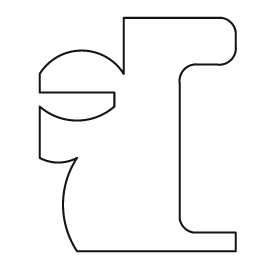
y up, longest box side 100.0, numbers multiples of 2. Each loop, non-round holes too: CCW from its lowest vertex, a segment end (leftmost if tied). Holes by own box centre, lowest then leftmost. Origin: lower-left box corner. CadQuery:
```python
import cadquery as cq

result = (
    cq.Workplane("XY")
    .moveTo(16.0, 0.0)
    .lineTo(84.0, 0.0)
    .lineTo(84.0, 8.0)
    .lineTo(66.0, 8.0)
    .threePointArc((62.0, 10.0), (60.0, 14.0))
    .lineTo(60.0, 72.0)
    .threePointArc((62.0, 78.0), (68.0, 80.0))
    .lineTo(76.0, 80.0)
    .threePointArc((82.0, 82.0), (84.0, 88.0))
    .lineTo(84.0, 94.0)
    .threePointArc((82.0, 98.0), (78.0, 100.0))
    .lineTo(36.0, 100.0)
    .lineTo(36.0, 76.0)
    .threePointArc((18.0, 86.0), (0.0, 76.0))
    .lineTo(0.0, 68.0)
    .lineTo(32.0, 68.0)
    .lineTo(32.0, 62.0)
    .threePointArc((16.0, 56.0), (0.0, 62.0))
    .lineTo(0.0, 40.0)
    .threePointArc((8.0, 38.0), (16.0, 40.0))
    .threePointArc((10.0, 20.0), (16.0, 0.0))
    .close()
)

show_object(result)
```